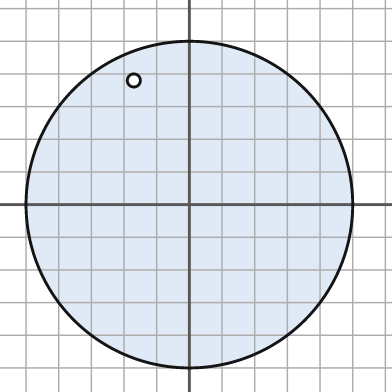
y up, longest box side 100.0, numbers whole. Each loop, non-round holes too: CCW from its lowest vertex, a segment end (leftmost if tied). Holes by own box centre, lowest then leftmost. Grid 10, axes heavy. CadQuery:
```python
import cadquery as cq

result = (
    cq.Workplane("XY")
    .moveTo(0.0, 0.0)
    .circle(50.0)
    .moveTo(-17.0, 38.0)
    .circle(2.0)
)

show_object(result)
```